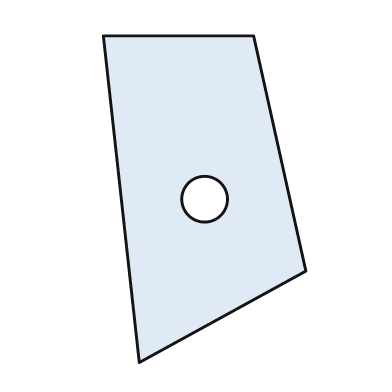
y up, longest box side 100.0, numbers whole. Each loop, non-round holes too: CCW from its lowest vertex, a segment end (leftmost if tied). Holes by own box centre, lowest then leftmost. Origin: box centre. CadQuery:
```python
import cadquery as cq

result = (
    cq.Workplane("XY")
    .moveTo(-20.0, -50.0)
    .lineTo(31.0, -22.0)
    .lineTo(15.0, 50.0)
    .lineTo(-31.0, 50.0)
    .close()
    .moveTo(0.0, 0.0)
    .circle(7.0)
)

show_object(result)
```